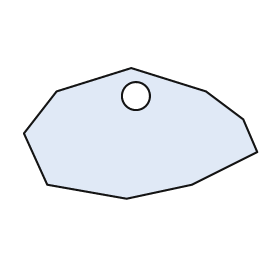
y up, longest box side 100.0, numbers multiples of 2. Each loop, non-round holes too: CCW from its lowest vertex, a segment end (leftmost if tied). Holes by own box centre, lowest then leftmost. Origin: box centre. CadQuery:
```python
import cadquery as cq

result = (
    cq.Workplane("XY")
    .moveTo(-6.0, -28.0)
    .lineTo(22.0, -22.0)
    .lineTo(50.0, -8.0)
    .lineTo(44.0, 6.0)
    .lineTo(28.0, 18.0)
    .lineTo(-4.0, 28.0)
    .lineTo(-36.0, 18.0)
    .lineTo(-50.0, 0.0)
    .lineTo(-40.0, -22.0)
    .close()
    .moveTo(-2.0, 16.0)
    .circle(6.0)
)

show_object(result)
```